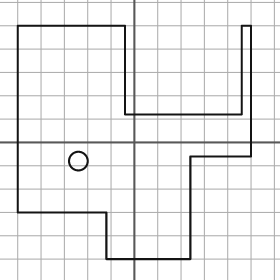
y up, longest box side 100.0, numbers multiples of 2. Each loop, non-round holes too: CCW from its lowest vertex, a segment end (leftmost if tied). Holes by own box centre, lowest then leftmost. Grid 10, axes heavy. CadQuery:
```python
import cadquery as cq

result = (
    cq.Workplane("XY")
    .moveTo(-12.0, -50.0)
    .lineTo(24.0, -50.0)
    .lineTo(24.0, -6.0)
    .lineTo(50.0, -6.0)
    .lineTo(50.0, 50.0)
    .lineTo(46.0, 50.0)
    .lineTo(46.0, 12.0)
    .lineTo(-4.0, 12.0)
    .lineTo(-4.0, 50.0)
    .lineTo(-50.0, 50.0)
    .lineTo(-50.0, -30.0)
    .lineTo(-12.0, -30.0)
    .close()
    .moveTo(-24.0, -8.0)
    .circle(4.0)
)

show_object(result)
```